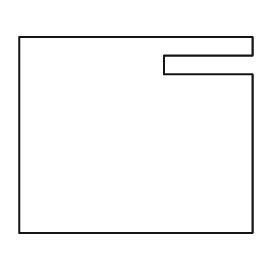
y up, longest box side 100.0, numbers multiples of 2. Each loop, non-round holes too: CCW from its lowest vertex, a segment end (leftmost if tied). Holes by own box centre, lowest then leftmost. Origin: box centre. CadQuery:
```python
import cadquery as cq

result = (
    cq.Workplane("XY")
    .moveTo(-50.0, -42.0)
    .lineTo(50.0, -42.0)
    .lineTo(50.0, 26.0)
    .lineTo(12.0, 26.0)
    .lineTo(12.0, 34.0)
    .lineTo(50.0, 34.0)
    .lineTo(50.0, 42.0)
    .lineTo(-50.0, 42.0)
    .close()
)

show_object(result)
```